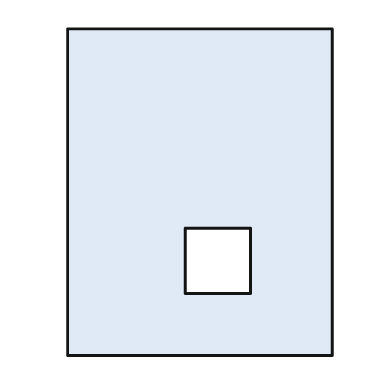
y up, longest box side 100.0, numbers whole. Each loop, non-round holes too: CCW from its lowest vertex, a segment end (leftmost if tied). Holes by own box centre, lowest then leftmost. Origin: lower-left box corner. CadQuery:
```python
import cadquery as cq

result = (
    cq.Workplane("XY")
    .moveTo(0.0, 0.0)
    .lineTo(81.0, 0.0)
    .lineTo(81.0, 100.0)
    .lineTo(0.0, 100.0)
    .close()
    .moveTo(36.0, 19.0)
    .lineTo(56.0, 19.0)
    .lineTo(56.0, 39.0)
    .lineTo(36.0, 39.0)
    .close()
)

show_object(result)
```